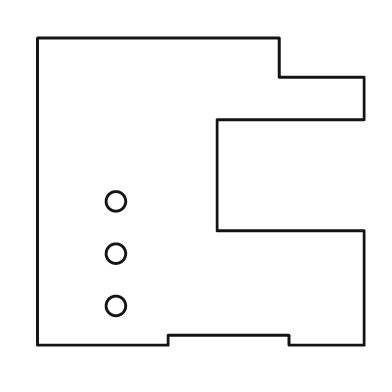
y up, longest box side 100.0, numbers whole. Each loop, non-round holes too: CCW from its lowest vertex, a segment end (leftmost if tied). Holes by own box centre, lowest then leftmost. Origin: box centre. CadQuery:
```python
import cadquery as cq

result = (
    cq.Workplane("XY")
    .moveTo(-50.0, -47.0)
    .lineTo(-10.0, -47.0)
    .lineTo(-10.0, -44.0)
    .lineTo(27.0, -44.0)
    .lineTo(27.0, -47.0)
    .lineTo(50.0, -47.0)
    .lineTo(50.0, -12.0)
    .lineTo(5.0, -12.0)
    .lineTo(5.0, 22.0)
    .lineTo(50.0, 22.0)
    .lineTo(50.0, 35.0)
    .lineTo(24.0, 35.0)
    .lineTo(24.0, 47.0)
    .lineTo(-50.0, 47.0)
    .close()
    .moveTo(-26.0, -35.0)
    .circle(3.0)
    .moveTo(-26.0, -19.0)
    .circle(3.0)
    .moveTo(-26.0, -3.0)
    .circle(3.0)
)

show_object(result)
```